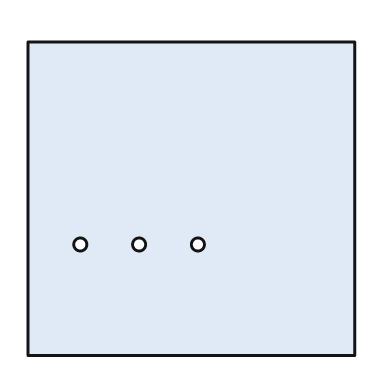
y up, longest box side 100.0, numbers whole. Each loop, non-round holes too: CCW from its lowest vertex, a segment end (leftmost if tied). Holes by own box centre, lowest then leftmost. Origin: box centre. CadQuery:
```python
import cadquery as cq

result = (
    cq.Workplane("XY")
    .moveTo(-50.0, -48.0)
    .lineTo(50.0, -48.0)
    .lineTo(50.0, 48.0)
    .lineTo(-50.0, 48.0)
    .close()
    .moveTo(-34.0, -14.0)
    .circle(2.0)
    .moveTo(-16.0, -14.0)
    .circle(2.0)
    .moveTo(2.0, -14.0)
    .circle(2.0)
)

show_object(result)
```